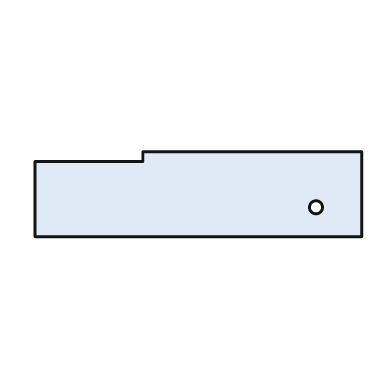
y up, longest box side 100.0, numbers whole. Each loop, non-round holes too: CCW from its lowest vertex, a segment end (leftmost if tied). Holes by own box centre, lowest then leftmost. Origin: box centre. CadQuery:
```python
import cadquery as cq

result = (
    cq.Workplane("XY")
    .moveTo(-50.0, -13.0)
    .lineTo(50.0, -13.0)
    .lineTo(50.0, 13.0)
    .lineTo(-17.0, 13.0)
    .lineTo(-17.0, 10.0)
    .lineTo(-50.0, 10.0)
    .close()
    .moveTo(36.0, -4.0)
    .circle(2.0)
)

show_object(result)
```